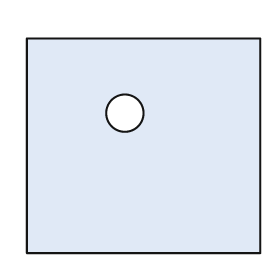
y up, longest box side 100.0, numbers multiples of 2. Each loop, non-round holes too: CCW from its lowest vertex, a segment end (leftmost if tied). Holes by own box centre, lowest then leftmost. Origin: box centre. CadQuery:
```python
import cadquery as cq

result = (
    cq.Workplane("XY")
    .moveTo(-50.0, -46.0)
    .lineTo(50.0, -46.0)
    .lineTo(50.0, 46.0)
    .lineTo(-50.0, 46.0)
    .close()
    .moveTo(-8.0, 14.0)
    .circle(8.0)
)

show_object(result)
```